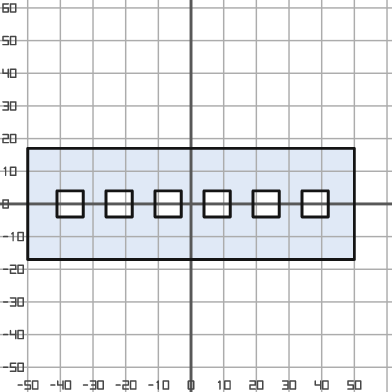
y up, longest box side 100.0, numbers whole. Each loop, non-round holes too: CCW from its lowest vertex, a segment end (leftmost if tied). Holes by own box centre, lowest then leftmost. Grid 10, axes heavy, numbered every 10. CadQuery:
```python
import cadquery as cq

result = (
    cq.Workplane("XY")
    .moveTo(-50.0, -17.0)
    .lineTo(50.0, -17.0)
    .lineTo(50.0, 17.0)
    .lineTo(-50.0, 17.0)
    .close()
    .moveTo(-41.0, -4.0)
    .lineTo(-33.0, -4.0)
    .lineTo(-33.0, 4.0)
    .lineTo(-41.0, 4.0)
    .close()
    .moveTo(-26.0, -4.0)
    .lineTo(-18.0, -4.0)
    .lineTo(-18.0, 4.0)
    .lineTo(-26.0, 4.0)
    .close()
    .moveTo(-11.0, -4.0)
    .lineTo(-3.0, -4.0)
    .lineTo(-3.0, 4.0)
    .lineTo(-11.0, 4.0)
    .close()
    .moveTo(4.0, -4.0)
    .lineTo(12.0, -4.0)
    .lineTo(12.0, 4.0)
    .lineTo(4.0, 4.0)
    .close()
    .moveTo(19.0, -4.0)
    .lineTo(27.0, -4.0)
    .lineTo(27.0, 4.0)
    .lineTo(19.0, 4.0)
    .close()
    .moveTo(34.0, -4.0)
    .lineTo(42.0, -4.0)
    .lineTo(42.0, 4.0)
    .lineTo(34.0, 4.0)
    .close()
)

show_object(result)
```